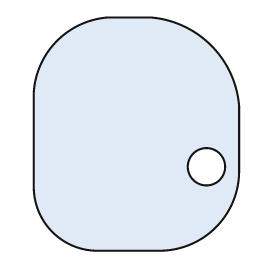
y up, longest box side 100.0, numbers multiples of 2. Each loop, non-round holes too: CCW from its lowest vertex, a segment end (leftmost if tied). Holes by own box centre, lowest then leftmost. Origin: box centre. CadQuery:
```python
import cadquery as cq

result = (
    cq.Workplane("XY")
    .moveTo(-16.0, -50.0)
    .lineTo(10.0, -50.0)
    .threePointArc((34.0, -40.0), (44.0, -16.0))
    .lineTo(44.0, 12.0)
    .threePointArc((32.0, 38.0), (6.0, 50.0))
    .lineTo(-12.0, 50.0)
    .threePointArc((-34.0, 40.0), (-44.0, 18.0))
    .lineTo(-44.0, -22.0)
    .threePointArc((-36.0, -42.0), (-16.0, -50.0))
    .close()
    .moveTo(30.0, -14.0)
    .circle(8.0)
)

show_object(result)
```